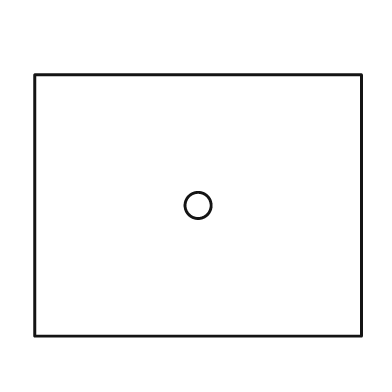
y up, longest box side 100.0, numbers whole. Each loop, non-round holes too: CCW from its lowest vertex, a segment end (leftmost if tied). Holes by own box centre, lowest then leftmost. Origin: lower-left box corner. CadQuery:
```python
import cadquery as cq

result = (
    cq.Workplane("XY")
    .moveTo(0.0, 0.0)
    .lineTo(100.0, 0.0)
    .lineTo(100.0, 80.0)
    .lineTo(0.0, 80.0)
    .close()
    .moveTo(50.0, 40.0)
    .circle(4.0)
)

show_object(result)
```